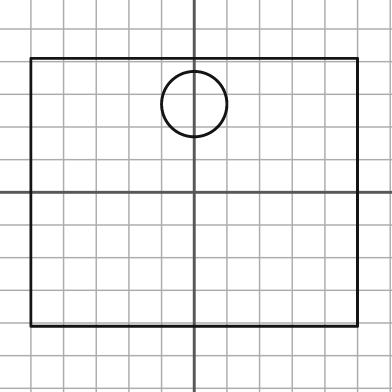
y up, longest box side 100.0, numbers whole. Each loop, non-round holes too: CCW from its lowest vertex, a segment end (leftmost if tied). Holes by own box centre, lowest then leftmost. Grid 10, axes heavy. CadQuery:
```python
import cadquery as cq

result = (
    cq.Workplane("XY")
    .moveTo(-50.0, -41.0)
    .lineTo(50.0, -41.0)
    .lineTo(50.0, 41.0)
    .lineTo(-50.0, 41.0)
    .close()
    .moveTo(0.0, 27.0)
    .circle(10.0)
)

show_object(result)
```